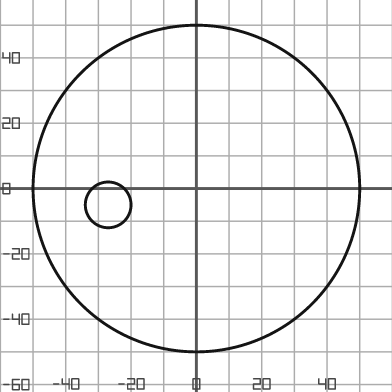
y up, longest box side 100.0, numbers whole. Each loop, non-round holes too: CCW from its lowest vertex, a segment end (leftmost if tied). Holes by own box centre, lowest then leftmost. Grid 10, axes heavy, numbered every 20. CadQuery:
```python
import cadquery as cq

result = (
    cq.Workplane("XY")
    .moveTo(0.0, 0.0)
    .circle(50.0)
    .moveTo(-27.0, -5.0)
    .circle(7.0)
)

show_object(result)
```